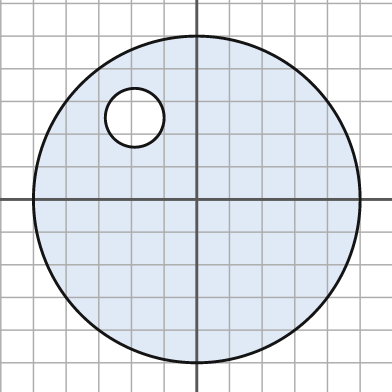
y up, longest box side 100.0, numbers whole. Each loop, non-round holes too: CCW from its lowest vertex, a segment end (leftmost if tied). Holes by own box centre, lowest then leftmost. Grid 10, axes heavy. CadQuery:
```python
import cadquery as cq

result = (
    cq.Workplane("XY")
    .moveTo(0.0, 0.0)
    .circle(50.0)
    .moveTo(-19.0, 25.0)
    .circle(9.0)
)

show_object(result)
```